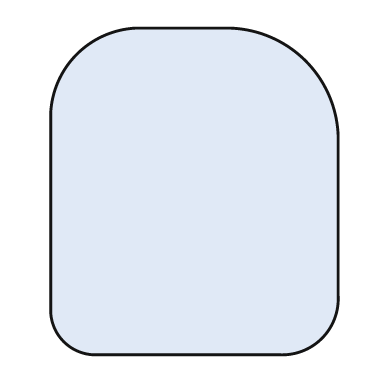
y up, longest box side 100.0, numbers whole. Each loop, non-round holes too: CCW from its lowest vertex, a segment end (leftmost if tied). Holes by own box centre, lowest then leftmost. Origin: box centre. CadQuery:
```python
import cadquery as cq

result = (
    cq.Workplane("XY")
    .moveTo(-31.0, -50.0)
    .lineTo(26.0, -50.0)
    .threePointArc((39.0, -45.0), (44.0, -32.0))
    .lineTo(44.0, 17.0)
    .threePointArc((34.0, 40.0), (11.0, 50.0))
    .lineTo(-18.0, 50.0)
    .threePointArc((-36.0, 42.0), (-44.0, 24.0))
    .lineTo(-44.0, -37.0)
    .threePointArc((-40.0, -46.0), (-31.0, -50.0))
    .close()
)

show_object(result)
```